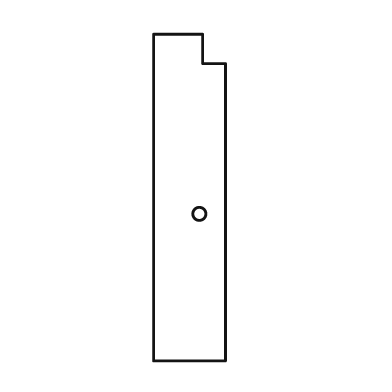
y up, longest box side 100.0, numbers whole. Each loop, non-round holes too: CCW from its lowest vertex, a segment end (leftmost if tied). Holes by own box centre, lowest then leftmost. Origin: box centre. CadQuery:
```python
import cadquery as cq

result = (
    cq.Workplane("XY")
    .moveTo(-11.0, -50.0)
    .lineTo(11.0, -50.0)
    .lineTo(11.0, 41.0)
    .lineTo(4.0, 41.0)
    .lineTo(4.0, 50.0)
    .lineTo(-11.0, 50.0)
    .close()
    .moveTo(3.0, -5.0)
    .circle(2.0)
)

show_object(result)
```